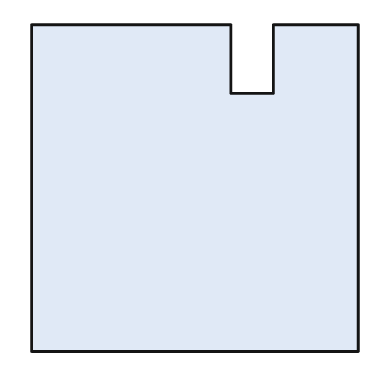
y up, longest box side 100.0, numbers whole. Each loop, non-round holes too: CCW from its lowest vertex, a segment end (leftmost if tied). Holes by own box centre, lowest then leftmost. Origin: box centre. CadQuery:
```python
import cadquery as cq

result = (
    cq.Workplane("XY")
    .moveTo(-50.0, -50.0)
    .lineTo(50.0, -50.0)
    .lineTo(50.0, 50.0)
    .lineTo(24.0, 50.0)
    .lineTo(24.0, 29.0)
    .lineTo(11.0, 29.0)
    .lineTo(11.0, 50.0)
    .lineTo(-50.0, 50.0)
    .close()
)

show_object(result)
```